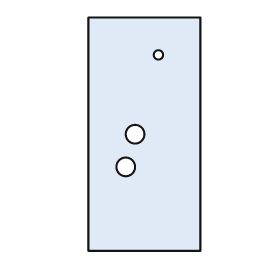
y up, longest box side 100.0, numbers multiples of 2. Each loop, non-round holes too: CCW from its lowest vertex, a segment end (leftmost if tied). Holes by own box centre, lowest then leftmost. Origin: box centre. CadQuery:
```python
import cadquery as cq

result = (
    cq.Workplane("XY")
    .moveTo(-24.0, -50.0)
    .lineTo(24.0, -50.0)
    .lineTo(24.0, 50.0)
    .lineTo(-24.0, 50.0)
    .close()
    .moveTo(-8.0, -14.0)
    .circle(4.0)
    .moveTo(-4.0, 0.0)
    .circle(4.0)
    .moveTo(6.0, 34.0)
    .circle(2.0)
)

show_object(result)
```